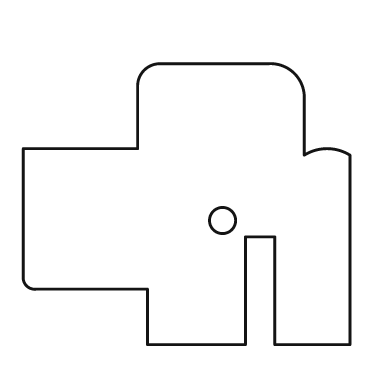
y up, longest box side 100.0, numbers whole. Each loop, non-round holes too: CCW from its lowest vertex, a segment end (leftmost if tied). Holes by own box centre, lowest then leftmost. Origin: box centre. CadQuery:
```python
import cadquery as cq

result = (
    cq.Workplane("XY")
    .moveTo(-12.0, -43.0)
    .lineTo(18.0, -43.0)
    .lineTo(18.0, -10.0)
    .lineTo(27.0, -10.0)
    .lineTo(27.0, -43.0)
    .lineTo(50.0, -43.0)
    .lineTo(50.0, 15.0)
    .threePointArc((43.0, 17.0), (36.0, 15.0))
    .lineTo(36.0, 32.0)
    .threePointArc((33.0, 40.0), (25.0, 43.0))
    .lineTo(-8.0, 43.0)
    .threePointArc((-13.0, 41.0), (-15.0, 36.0))
    .lineTo(-15.0, 17.0)
    .lineTo(-50.0, 17.0)
    .lineTo(-50.0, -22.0)
    .threePointArc((-49.0, -25.0), (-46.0, -26.0))
    .lineTo(-12.0, -26.0)
    .close()
    .moveTo(11.0, -5.0)
    .circle(4.0)
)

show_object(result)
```